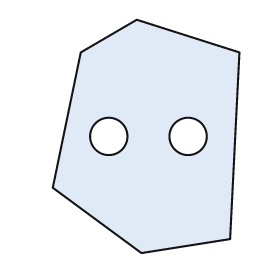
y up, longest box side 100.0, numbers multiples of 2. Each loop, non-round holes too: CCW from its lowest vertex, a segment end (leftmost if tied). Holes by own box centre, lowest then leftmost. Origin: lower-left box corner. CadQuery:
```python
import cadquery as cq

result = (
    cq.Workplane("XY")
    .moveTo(38.0, 0.0)
    .lineTo(76.0, 6.0)
    .lineTo(80.0, 86.0)
    .lineTo(36.0, 100.0)
    .lineTo(12.0, 86.0)
    .lineTo(0.0, 28.0)
    .close()
    .moveTo(24.0, 50.0)
    .circle(8.0)
    .moveTo(58.0, 50.0)
    .circle(8.0)
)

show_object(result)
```